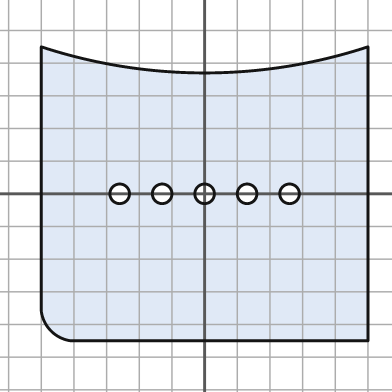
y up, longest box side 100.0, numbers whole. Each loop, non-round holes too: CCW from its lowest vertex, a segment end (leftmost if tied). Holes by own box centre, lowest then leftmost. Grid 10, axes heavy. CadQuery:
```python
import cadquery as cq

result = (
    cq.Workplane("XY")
    .moveTo(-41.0, -45.0)
    .lineTo(50.0, -45.0)
    .lineTo(50.0, 45.0)
    .threePointArc((0.0, 37.0), (-50.0, 45.0))
    .lineTo(-50.0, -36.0)
    .threePointArc((-47.0, -42.0), (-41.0, -45.0))
    .close()
    .moveTo(-26.0, 0.0)
    .circle(3.0)
    .moveTo(-13.0, 0.0)
    .circle(3.0)
    .moveTo(0.0, 0.0)
    .circle(3.0)
    .moveTo(13.0, 0.0)
    .circle(3.0)
    .moveTo(26.0, 0.0)
    .circle(3.0)
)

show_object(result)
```